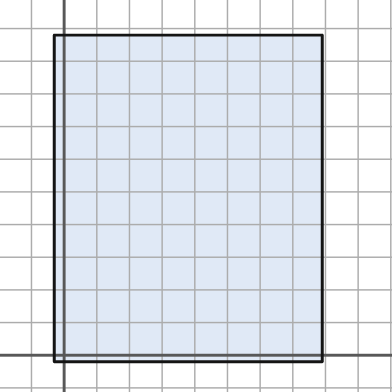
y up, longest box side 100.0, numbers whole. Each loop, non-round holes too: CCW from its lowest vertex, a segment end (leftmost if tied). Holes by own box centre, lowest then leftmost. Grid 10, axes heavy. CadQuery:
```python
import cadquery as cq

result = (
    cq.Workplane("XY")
    .moveTo(-3.0, -2.0)
    .lineTo(79.0, -2.0)
    .lineTo(79.0, 98.0)
    .lineTo(-3.0, 98.0)
    .close()
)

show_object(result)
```